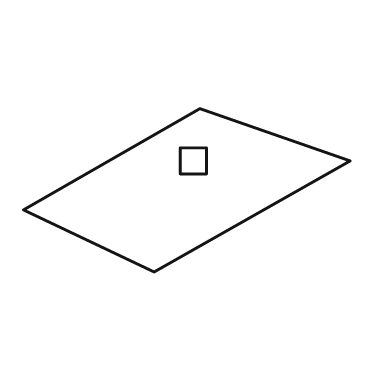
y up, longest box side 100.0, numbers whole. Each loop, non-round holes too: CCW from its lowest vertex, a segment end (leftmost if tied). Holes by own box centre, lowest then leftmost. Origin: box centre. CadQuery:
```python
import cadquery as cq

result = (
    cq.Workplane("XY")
    .moveTo(-10.0, -25.0)
    .lineTo(50.0, 9.0)
    .lineTo(4.0, 25.0)
    .lineTo(-50.0, -6.0)
    .close()
    .moveTo(-2.0, 5.0)
    .lineTo(6.0, 5.0)
    .lineTo(6.0, 13.0)
    .lineTo(-2.0, 13.0)
    .close()
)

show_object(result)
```